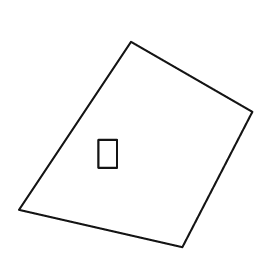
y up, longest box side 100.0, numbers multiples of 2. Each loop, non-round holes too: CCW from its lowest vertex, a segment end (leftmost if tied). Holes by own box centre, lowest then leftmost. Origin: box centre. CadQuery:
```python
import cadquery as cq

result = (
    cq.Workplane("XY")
    .moveTo(20.0, -44.0)
    .lineTo(50.0, 14.0)
    .lineTo(-2.0, 44.0)
    .lineTo(-50.0, -28.0)
    .close()
    .moveTo(-16.0, -10.0)
    .lineTo(-8.0, -10.0)
    .lineTo(-8.0, 2.0)
    .lineTo(-16.0, 2.0)
    .close()
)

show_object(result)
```